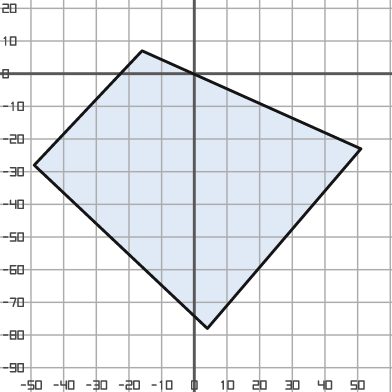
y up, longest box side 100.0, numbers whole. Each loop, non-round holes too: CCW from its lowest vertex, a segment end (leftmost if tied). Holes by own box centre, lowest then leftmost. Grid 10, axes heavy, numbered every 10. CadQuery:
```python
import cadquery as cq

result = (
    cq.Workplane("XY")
    .moveTo(4.0, -78.0)
    .lineTo(51.0, -23.0)
    .lineTo(-16.0, 7.0)
    .lineTo(-49.0, -28.0)
    .close()
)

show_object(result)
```